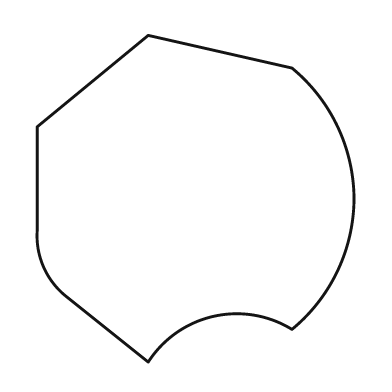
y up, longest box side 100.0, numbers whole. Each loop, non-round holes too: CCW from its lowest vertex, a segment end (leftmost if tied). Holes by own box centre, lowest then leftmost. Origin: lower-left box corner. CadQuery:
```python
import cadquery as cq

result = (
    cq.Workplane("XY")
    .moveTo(34.0, 0.0)
    .threePointArc((54.0, 14.0), (78.0, 10.0))
    .threePointArc((92.0, 28.0), (97.0, 50.0))
    .threePointArc((92.0, 72.0), (78.0, 90.0))
    .lineTo(34.0, 100.0)
    .lineTo(0.0, 72.0)
    .lineTo(0.0, 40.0)
    .threePointArc((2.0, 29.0), (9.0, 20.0))
    .close()
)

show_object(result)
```